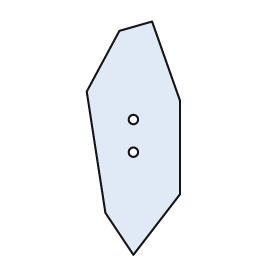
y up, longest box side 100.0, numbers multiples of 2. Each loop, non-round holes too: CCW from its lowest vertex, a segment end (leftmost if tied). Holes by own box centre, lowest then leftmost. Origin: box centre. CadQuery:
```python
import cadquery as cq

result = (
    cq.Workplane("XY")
    .moveTo(0.0, -50.0)
    .lineTo(20.0, -24.0)
    .lineTo(20.0, 16.0)
    .lineTo(8.0, 50.0)
    .lineTo(-6.0, 46.0)
    .lineTo(-20.0, 20.0)
    .lineTo(-12.0, -32.0)
    .close()
    .moveTo(0.0, -6.0)
    .circle(2.0)
    .moveTo(0.0, 8.0)
    .circle(2.0)
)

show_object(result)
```